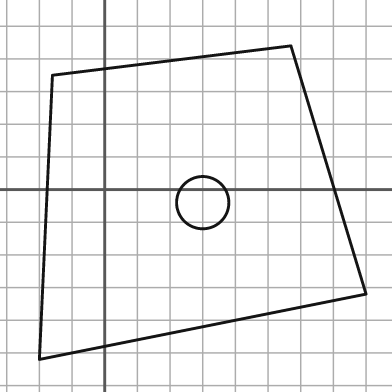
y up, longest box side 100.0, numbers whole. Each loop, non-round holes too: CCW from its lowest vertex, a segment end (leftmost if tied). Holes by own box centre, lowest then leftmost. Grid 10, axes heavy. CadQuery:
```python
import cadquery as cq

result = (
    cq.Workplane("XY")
    .moveTo(-20.0, -52.0)
    .lineTo(80.0, -32.0)
    .lineTo(57.0, 44.0)
    .lineTo(-16.0, 35.0)
    .close()
    .moveTo(30.0, -4.0)
    .circle(8.0)
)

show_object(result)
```